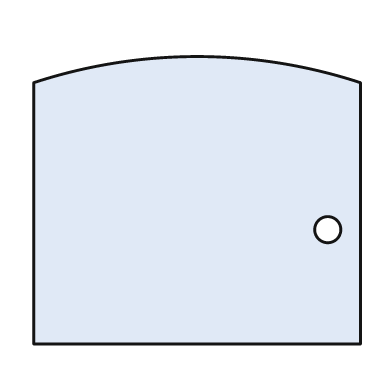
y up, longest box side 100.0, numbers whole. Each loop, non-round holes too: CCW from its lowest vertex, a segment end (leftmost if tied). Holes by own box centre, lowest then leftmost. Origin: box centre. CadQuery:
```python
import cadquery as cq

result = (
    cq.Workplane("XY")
    .moveTo(-50.0, -44.0)
    .lineTo(50.0, -44.0)
    .lineTo(50.0, 36.0)
    .threePointArc((0.0, 44.0), (-50.0, 36.0))
    .close()
    .moveTo(40.0, -9.0)
    .circle(4.0)
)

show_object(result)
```